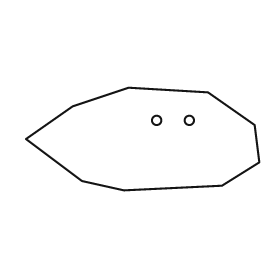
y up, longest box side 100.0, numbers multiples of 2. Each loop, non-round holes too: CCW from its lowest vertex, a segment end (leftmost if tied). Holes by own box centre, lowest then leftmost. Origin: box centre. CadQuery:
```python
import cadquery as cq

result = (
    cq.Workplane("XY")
    .moveTo(-8.0, -22.0)
    .lineTo(34.0, -20.0)
    .lineTo(50.0, -10.0)
    .lineTo(48.0, 6.0)
    .lineTo(28.0, 20.0)
    .lineTo(-6.0, 22.0)
    .lineTo(-30.0, 14.0)
    .lineTo(-50.0, 0.0)
    .lineTo(-26.0, -18.0)
    .close()
    .moveTo(6.0, 8.0)
    .circle(2.0)
    .moveTo(20.0, 8.0)
    .circle(2.0)
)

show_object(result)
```